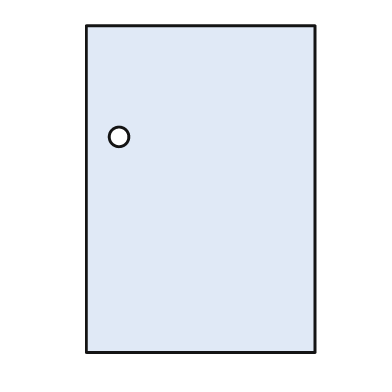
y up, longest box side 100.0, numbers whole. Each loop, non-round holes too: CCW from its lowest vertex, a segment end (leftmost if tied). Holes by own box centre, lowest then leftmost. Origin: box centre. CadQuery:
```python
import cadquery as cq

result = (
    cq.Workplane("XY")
    .moveTo(-35.0, -50.0)
    .lineTo(35.0, -50.0)
    .lineTo(35.0, 50.0)
    .lineTo(-35.0, 50.0)
    .close()
    .moveTo(-25.0, 16.0)
    .circle(3.0)
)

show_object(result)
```